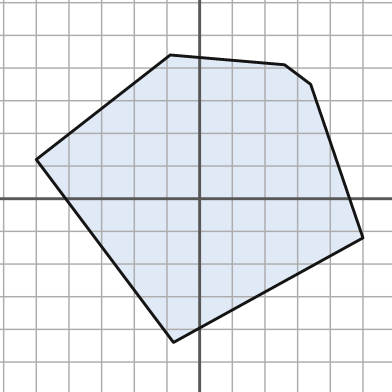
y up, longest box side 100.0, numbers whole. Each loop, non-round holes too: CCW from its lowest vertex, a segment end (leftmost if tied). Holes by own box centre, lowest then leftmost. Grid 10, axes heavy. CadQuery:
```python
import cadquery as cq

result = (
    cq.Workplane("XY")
    .moveTo(-8.0, -44.0)
    .lineTo(50.0, -12.0)
    .lineTo(34.0, 35.0)
    .lineTo(26.0, 41.0)
    .lineTo(-9.0, 44.0)
    .lineTo(-50.0, 12.0)
    .close()
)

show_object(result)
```